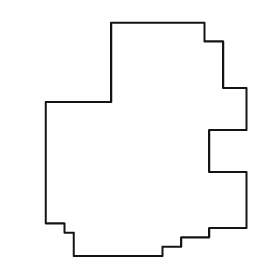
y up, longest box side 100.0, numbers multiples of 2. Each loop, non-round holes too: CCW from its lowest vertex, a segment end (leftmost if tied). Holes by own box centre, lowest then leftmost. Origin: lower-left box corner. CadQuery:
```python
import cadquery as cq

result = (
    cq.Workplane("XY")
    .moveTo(12.0, 0.0)
    .lineTo(50.0, 0.0)
    .lineTo(50.0, 4.0)
    .lineTo(58.0, 4.0)
    .lineTo(58.0, 8.0)
    .lineTo(70.0, 8.0)
    .lineTo(70.0, 12.0)
    .lineTo(86.0, 12.0)
    .lineTo(86.0, 36.0)
    .lineTo(70.0, 36.0)
    .lineTo(70.0, 54.0)
    .lineTo(86.0, 54.0)
    .lineTo(86.0, 72.0)
    .lineTo(76.0, 72.0)
    .lineTo(76.0, 92.0)
    .lineTo(68.0, 92.0)
    .lineTo(68.0, 100.0)
    .lineTo(28.0, 100.0)
    .lineTo(28.0, 66.0)
    .lineTo(0.0, 66.0)
    .lineTo(0.0, 14.0)
    .lineTo(8.0, 14.0)
    .lineTo(8.0, 10.0)
    .lineTo(12.0, 10.0)
    .close()
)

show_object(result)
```